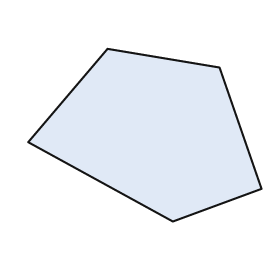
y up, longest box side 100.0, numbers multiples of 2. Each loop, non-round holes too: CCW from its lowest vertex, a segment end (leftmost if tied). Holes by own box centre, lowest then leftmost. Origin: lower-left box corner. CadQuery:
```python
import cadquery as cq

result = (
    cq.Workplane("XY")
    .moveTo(62.0, 0.0)
    .lineTo(100.0, 14.0)
    .lineTo(82.0, 66.0)
    .lineTo(34.0, 74.0)
    .lineTo(0.0, 34.0)
    .close()
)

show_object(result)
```